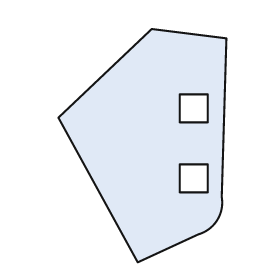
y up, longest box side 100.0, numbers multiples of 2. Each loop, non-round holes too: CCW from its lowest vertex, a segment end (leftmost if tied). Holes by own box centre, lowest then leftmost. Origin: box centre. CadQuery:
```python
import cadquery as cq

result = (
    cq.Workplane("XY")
    .moveTo(-2.0, -50.0)
    .lineTo(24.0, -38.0)
    .threePointArc((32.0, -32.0), (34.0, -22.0))
    .lineTo(36.0, 46.0)
    .lineTo(4.0, 50.0)
    .lineTo(-36.0, 12.0)
    .close()
    .moveTo(16.0, -20.0)
    .lineTo(28.0, -20.0)
    .lineTo(28.0, -8.0)
    .lineTo(16.0, -8.0)
    .close()
    .moveTo(16.0, 10.0)
    .lineTo(28.0, 10.0)
    .lineTo(28.0, 22.0)
    .lineTo(16.0, 22.0)
    .close()
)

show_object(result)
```